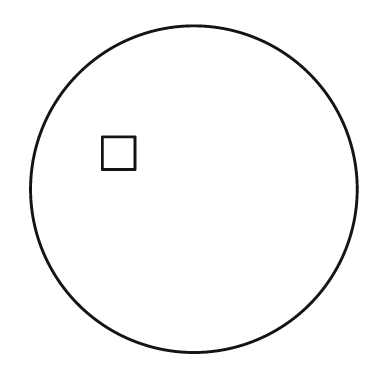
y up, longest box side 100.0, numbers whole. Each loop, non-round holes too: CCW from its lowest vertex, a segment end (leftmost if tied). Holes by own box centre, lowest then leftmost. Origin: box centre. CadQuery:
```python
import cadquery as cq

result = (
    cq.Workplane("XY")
    .moveTo(0.0, 0.0)
    .circle(50.0)
    .moveTo(-28.0, 6.0)
    .lineTo(-18.0, 6.0)
    .lineTo(-18.0, 16.0)
    .lineTo(-28.0, 16.0)
    .close()
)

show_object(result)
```